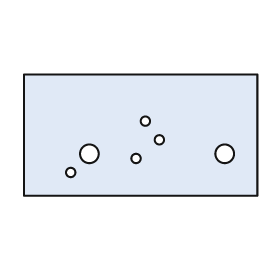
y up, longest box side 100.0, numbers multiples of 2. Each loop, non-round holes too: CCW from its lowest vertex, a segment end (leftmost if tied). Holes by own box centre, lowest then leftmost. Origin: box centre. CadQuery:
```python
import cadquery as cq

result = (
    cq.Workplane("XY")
    .moveTo(-50.0, -26.0)
    .lineTo(50.0, -26.0)
    .lineTo(50.0, 26.0)
    .lineTo(-50.0, 26.0)
    .close()
    .moveTo(-30.0, -16.0)
    .circle(2.0)
    .moveTo(-2.0, -10.0)
    .circle(2.0)
    .moveTo(-22.0, -8.0)
    .circle(4.0)
    .moveTo(36.0, -8.0)
    .circle(4.0)
    .moveTo(8.0, -2.0)
    .circle(2.0)
    .moveTo(2.0, 6.0)
    .circle(2.0)
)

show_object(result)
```